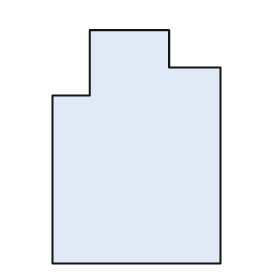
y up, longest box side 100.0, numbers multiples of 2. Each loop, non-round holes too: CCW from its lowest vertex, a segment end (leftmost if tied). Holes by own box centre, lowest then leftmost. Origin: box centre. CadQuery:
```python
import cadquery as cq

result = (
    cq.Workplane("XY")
    .moveTo(-36.0, -50.0)
    .lineTo(36.0, -50.0)
    .lineTo(36.0, 34.0)
    .lineTo(14.0, 34.0)
    .lineTo(14.0, 50.0)
    .lineTo(-20.0, 50.0)
    .lineTo(-20.0, 22.0)
    .lineTo(-36.0, 22.0)
    .close()
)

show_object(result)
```